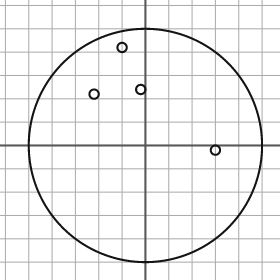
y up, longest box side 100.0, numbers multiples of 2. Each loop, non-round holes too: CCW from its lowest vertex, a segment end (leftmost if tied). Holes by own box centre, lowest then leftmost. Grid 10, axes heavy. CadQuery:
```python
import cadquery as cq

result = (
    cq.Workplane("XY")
    .moveTo(0.0, 0.0)
    .circle(50.0)
    .moveTo(30.0, -2.0)
    .circle(2.0)
    .moveTo(-22.0, 22.0)
    .circle(2.0)
    .moveTo(-2.0, 24.0)
    .circle(2.0)
    .moveTo(-10.0, 42.0)
    .circle(2.0)
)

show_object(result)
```